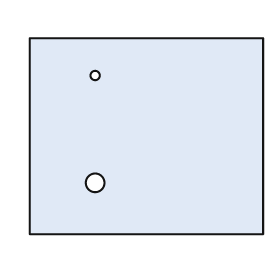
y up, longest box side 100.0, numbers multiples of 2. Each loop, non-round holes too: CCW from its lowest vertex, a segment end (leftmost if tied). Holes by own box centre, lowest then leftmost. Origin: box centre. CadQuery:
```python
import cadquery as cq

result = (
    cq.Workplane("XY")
    .moveTo(-50.0, -42.0)
    .lineTo(50.0, -42.0)
    .lineTo(50.0, 42.0)
    .lineTo(-50.0, 42.0)
    .close()
    .moveTo(-22.0, -20.0)
    .circle(4.0)
    .moveTo(-22.0, 26.0)
    .circle(2.0)
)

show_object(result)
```